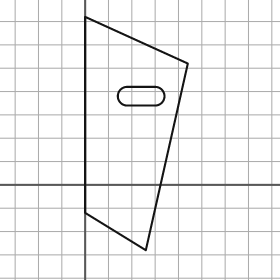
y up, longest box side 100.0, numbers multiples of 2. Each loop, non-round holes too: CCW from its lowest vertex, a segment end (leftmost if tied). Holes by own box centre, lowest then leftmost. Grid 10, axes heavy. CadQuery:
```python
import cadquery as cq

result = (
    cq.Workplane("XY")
    .moveTo(26.0, -28.0)
    .lineTo(44.0, 52.0)
    .lineTo(0.0, 72.0)
    .lineTo(0.0, -12.0)
    .close()
    .moveTo(18.0, 34.0)
    .lineTo(30.0, 34.0)
    .threePointArc((34.0, 38.0), (30.0, 42.0))
    .lineTo(18.0, 42.0)
    .threePointArc((14.0, 38.0), (18.0, 34.0))
    .close()
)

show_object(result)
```